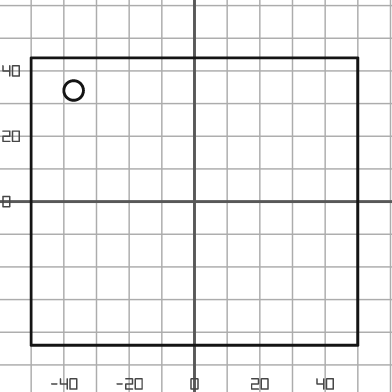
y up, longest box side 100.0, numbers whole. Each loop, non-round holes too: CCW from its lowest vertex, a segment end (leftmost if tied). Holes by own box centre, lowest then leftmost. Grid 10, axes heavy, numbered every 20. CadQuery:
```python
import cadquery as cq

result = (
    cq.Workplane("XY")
    .moveTo(-50.0, -44.0)
    .lineTo(50.0, -44.0)
    .lineTo(50.0, 44.0)
    .lineTo(-50.0, 44.0)
    .close()
    .moveTo(-37.0, 34.0)
    .circle(3.0)
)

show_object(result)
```